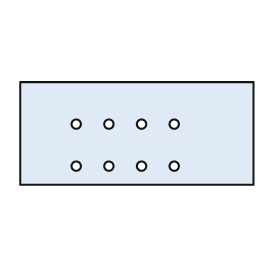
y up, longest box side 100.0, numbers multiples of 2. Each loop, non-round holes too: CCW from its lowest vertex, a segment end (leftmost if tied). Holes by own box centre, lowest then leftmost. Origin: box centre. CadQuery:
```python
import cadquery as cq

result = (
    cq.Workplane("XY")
    .moveTo(-50.0, -22.0)
    .lineTo(50.0, -22.0)
    .lineTo(50.0, 22.0)
    .lineTo(-50.0, 22.0)
    .close()
    .moveTo(-26.0, -14.0)
    .circle(2.0)
    .moveTo(-12.0, -14.0)
    .circle(2.0)
    .moveTo(2.0, -14.0)
    .circle(2.0)
    .moveTo(16.0, -14.0)
    .circle(2.0)
    .moveTo(-26.0, 4.0)
    .circle(2.0)
    .moveTo(-12.0, 4.0)
    .circle(2.0)
    .moveTo(2.0, 4.0)
    .circle(2.0)
    .moveTo(16.0, 4.0)
    .circle(2.0)
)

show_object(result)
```